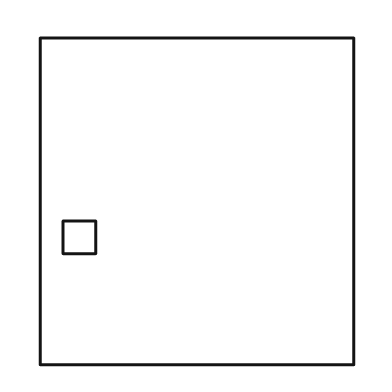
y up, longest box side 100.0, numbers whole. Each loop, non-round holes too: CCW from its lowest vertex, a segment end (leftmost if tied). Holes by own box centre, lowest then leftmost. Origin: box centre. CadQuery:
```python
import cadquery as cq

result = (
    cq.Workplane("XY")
    .moveTo(-48.0, -50.0)
    .lineTo(48.0, -50.0)
    .lineTo(48.0, 50.0)
    .lineTo(-48.0, 50.0)
    .close()
    .moveTo(-41.0, -16.0)
    .lineTo(-31.0, -16.0)
    .lineTo(-31.0, -6.0)
    .lineTo(-41.0, -6.0)
    .close()
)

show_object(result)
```